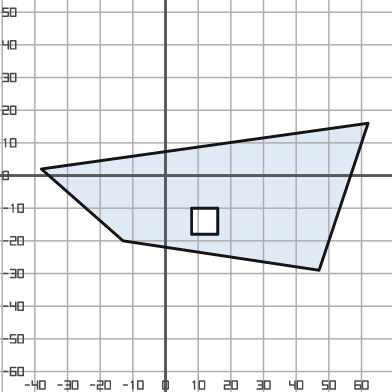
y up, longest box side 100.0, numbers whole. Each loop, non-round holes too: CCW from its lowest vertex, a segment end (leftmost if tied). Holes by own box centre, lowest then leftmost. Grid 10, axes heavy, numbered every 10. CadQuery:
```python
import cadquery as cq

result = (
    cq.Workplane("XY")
    .moveTo(47.0, -29.0)
    .lineTo(62.0, 16.0)
    .lineTo(-38.0, 2.0)
    .lineTo(-13.0, -20.0)
    .close()
    .moveTo(8.0, -18.0)
    .lineTo(16.0, -18.0)
    .lineTo(16.0, -10.0)
    .lineTo(8.0, -10.0)
    .close()
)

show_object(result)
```